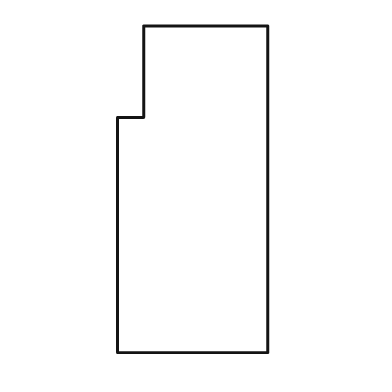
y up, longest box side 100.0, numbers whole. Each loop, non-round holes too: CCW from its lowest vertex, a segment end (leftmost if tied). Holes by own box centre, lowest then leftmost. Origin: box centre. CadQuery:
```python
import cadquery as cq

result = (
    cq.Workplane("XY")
    .moveTo(-23.0, -50.0)
    .lineTo(23.0, -50.0)
    .lineTo(23.0, 50.0)
    .lineTo(-15.0, 50.0)
    .lineTo(-15.0, 22.0)
    .lineTo(-23.0, 22.0)
    .close()
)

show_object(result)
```